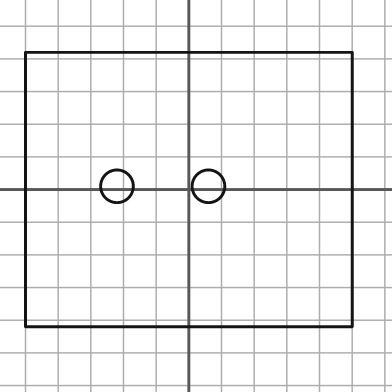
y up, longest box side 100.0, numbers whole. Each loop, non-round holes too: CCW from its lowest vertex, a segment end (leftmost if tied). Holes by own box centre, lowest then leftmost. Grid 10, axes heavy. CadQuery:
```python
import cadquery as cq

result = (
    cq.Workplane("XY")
    .moveTo(-50.0, -42.0)
    .lineTo(50.0, -42.0)
    .lineTo(50.0, 42.0)
    .lineTo(-50.0, 42.0)
    .close()
    .moveTo(-22.0, 1.0)
    .circle(5.0)
    .moveTo(6.0, 1.0)
    .circle(5.0)
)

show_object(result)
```